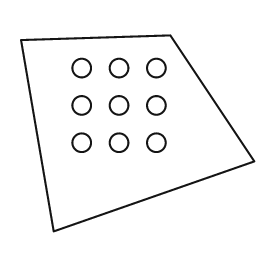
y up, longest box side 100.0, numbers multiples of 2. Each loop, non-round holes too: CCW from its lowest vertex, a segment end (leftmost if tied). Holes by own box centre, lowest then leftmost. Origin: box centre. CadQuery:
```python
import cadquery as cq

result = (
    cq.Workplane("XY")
    .moveTo(-36.0, -42.0)
    .lineTo(50.0, -12.0)
    .lineTo(14.0, 42.0)
    .lineTo(-50.0, 40.0)
    .close()
    .moveTo(-24.0, -4.0)
    .circle(4.0)
    .moveTo(-8.0, -4.0)
    .circle(4.0)
    .moveTo(8.0, -4.0)
    .circle(4.0)
    .moveTo(-24.0, 12.0)
    .circle(4.0)
    .moveTo(-8.0, 12.0)
    .circle(4.0)
    .moveTo(8.0, 12.0)
    .circle(4.0)
    .moveTo(-24.0, 28.0)
    .circle(4.0)
    .moveTo(-8.0, 28.0)
    .circle(4.0)
    .moveTo(8.0, 28.0)
    .circle(4.0)
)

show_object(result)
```